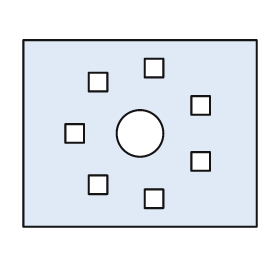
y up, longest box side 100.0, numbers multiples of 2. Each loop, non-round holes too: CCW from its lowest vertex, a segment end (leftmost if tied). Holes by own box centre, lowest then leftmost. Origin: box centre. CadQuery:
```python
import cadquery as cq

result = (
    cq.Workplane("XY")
    .moveTo(-50.0, -40.0)
    .lineTo(50.0, -40.0)
    .lineTo(50.0, 40.0)
    .lineTo(-50.0, 40.0)
    .close()
    .moveTo(2.0, -32.0)
    .lineTo(10.0, -32.0)
    .lineTo(10.0, -24.0)
    .lineTo(2.0, -24.0)
    .close()
    .moveTo(-22.0, -26.0)
    .lineTo(-14.0, -26.0)
    .lineTo(-14.0, -18.0)
    .lineTo(-22.0, -18.0)
    .close()
    .moveTo(22.0, -16.0)
    .lineTo(30.0, -16.0)
    .lineTo(30.0, -8.0)
    .lineTo(22.0, -8.0)
    .close()
    .moveTo(-32.0, -4.0)
    .lineTo(-24.0, -4.0)
    .lineTo(-24.0, 4.0)
    .lineTo(-32.0, 4.0)
    .close()
    .moveTo(0.0, 0.0)
    .circle(10.0)
    .moveTo(22.0, 8.0)
    .lineTo(30.0, 8.0)
    .lineTo(30.0, 16.0)
    .lineTo(22.0, 16.0)
    .close()
    .moveTo(-22.0, 18.0)
    .lineTo(-14.0, 18.0)
    .lineTo(-14.0, 26.0)
    .lineTo(-22.0, 26.0)
    .close()
    .moveTo(2.0, 24.0)
    .lineTo(10.0, 24.0)
    .lineTo(10.0, 32.0)
    .lineTo(2.0, 32.0)
    .close()
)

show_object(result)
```